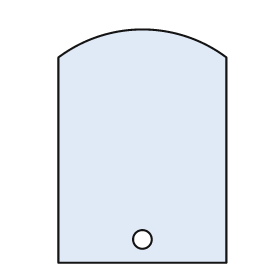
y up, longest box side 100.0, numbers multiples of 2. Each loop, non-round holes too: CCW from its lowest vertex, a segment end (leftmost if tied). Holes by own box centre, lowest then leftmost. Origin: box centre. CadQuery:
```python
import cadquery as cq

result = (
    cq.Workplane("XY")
    .moveTo(-36.0, -50.0)
    .lineTo(36.0, -50.0)
    .lineTo(36.0, 38.0)
    .threePointArc((0.0, 50.0), (-36.0, 38.0))
    .close()
    .moveTo(0.0, -40.0)
    .circle(4.0)
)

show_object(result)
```